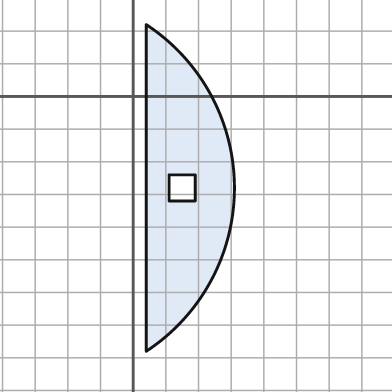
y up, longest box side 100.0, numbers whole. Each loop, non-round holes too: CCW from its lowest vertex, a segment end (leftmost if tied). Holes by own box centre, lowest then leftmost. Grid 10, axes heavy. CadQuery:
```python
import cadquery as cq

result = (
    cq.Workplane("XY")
    .moveTo(4.0, -78.0)
    .threePointArc((31.0, -28.0), (4.0, 22.0))
    .close()
    .moveTo(11.0, -32.0)
    .lineTo(19.0, -32.0)
    .lineTo(19.0, -24.0)
    .lineTo(11.0, -24.0)
    .close()
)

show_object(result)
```